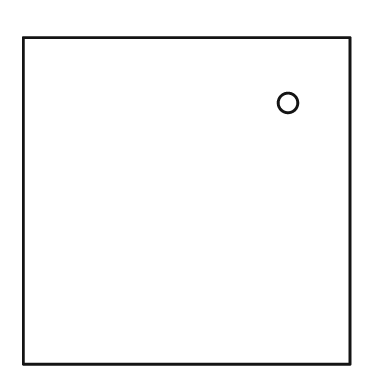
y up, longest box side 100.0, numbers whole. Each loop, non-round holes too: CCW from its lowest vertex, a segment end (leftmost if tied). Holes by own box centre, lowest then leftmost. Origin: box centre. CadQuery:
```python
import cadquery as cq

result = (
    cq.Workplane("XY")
    .moveTo(-50.0, -50.0)
    .lineTo(50.0, -50.0)
    .lineTo(50.0, 50.0)
    .lineTo(-50.0, 50.0)
    .close()
    .moveTo(31.0, 30.0)
    .circle(3.0)
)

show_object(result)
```